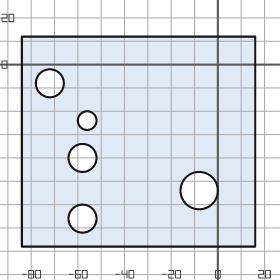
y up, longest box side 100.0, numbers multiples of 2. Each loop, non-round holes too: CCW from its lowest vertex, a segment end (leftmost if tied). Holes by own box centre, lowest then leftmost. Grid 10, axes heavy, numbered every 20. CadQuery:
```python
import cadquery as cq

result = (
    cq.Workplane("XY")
    .moveTo(-84.0, -78.0)
    .lineTo(16.0, -78.0)
    .lineTo(16.0, 12.0)
    .lineTo(-84.0, 12.0)
    .close()
    .moveTo(-58.0, -66.0)
    .circle(6.0)
    .moveTo(-8.0, -54.0)
    .circle(8.0)
    .moveTo(-58.0, -40.0)
    .circle(6.0)
    .moveTo(-56.0, -24.0)
    .circle(4.0)
    .moveTo(-72.0, -8.0)
    .circle(6.0)
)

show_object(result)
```